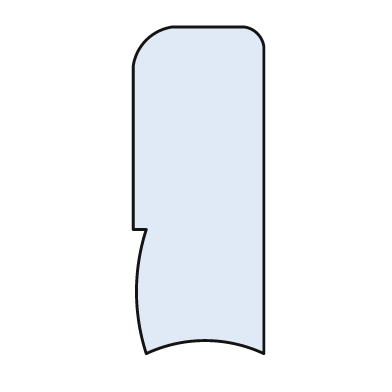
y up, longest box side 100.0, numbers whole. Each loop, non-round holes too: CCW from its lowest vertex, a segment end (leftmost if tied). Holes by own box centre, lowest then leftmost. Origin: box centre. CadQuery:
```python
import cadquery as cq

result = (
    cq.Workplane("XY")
    .moveTo(-16.0, -50.0)
    .threePointArc((2.0, -46.0), (20.0, -50.0))
    .lineTo(20.0, 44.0)
    .threePointArc((18.0, 48.0), (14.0, 50.0))
    .lineTo(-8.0, 50.0)
    .threePointArc((-16.0, 46.0), (-20.0, 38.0))
    .lineTo(-20.0, -12.0)
    .lineTo(-16.0, -12.0)
    .threePointArc((-19.0, -31.0), (-16.0, -50.0))
    .close()
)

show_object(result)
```